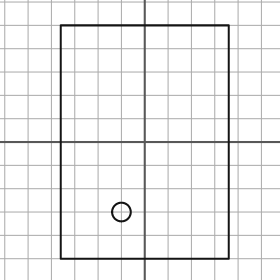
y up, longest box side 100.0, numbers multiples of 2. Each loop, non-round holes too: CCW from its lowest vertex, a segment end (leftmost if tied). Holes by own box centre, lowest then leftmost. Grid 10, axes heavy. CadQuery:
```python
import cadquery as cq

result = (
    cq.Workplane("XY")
    .moveTo(-36.0, -50.0)
    .lineTo(36.0, -50.0)
    .lineTo(36.0, 50.0)
    .lineTo(-36.0, 50.0)
    .close()
    .moveTo(-10.0, -30.0)
    .circle(4.0)
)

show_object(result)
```